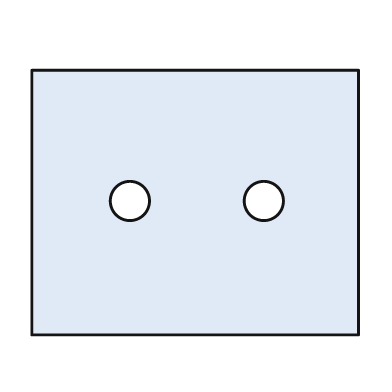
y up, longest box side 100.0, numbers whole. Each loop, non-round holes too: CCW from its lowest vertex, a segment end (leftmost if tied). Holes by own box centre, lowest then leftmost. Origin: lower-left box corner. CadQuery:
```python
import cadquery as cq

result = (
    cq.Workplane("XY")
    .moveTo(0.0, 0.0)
    .lineTo(100.0, 0.0)
    .lineTo(100.0, 81.0)
    .lineTo(0.0, 81.0)
    .close()
    .moveTo(30.0, 41.0)
    .circle(6.0)
    .moveTo(71.0, 41.0)
    .circle(6.0)
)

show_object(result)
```